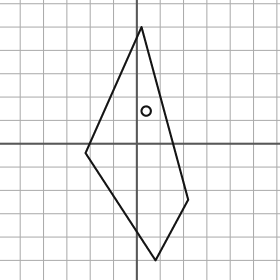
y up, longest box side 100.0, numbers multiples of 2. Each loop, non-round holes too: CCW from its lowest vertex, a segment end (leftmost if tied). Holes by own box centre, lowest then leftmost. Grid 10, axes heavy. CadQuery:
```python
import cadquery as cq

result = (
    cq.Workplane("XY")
    .moveTo(8.0, -50.0)
    .lineTo(22.0, -24.0)
    .lineTo(2.0, 50.0)
    .lineTo(-22.0, -4.0)
    .close()
    .moveTo(4.0, 14.0)
    .circle(2.0)
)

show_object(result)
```